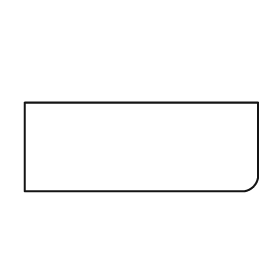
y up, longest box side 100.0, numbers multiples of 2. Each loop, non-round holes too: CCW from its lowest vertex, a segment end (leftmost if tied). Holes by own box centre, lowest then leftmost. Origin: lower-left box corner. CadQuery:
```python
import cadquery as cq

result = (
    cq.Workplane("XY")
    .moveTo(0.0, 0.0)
    .lineTo(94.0, 0.0)
    .threePointArc((98.0, 2.0), (100.0, 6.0))
    .lineTo(100.0, 38.0)
    .lineTo(0.0, 38.0)
    .close()
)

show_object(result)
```